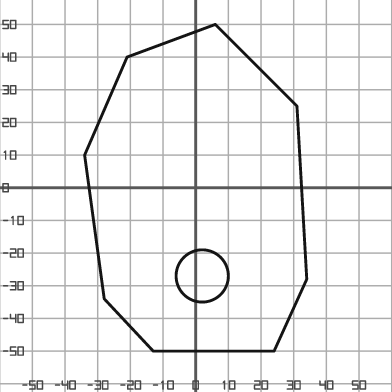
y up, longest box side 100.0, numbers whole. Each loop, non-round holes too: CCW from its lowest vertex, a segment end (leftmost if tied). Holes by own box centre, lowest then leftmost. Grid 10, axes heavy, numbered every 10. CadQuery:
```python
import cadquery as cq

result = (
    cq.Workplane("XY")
    .moveTo(-13.0, -50.0)
    .lineTo(24.0, -50.0)
    .lineTo(34.0, -28.0)
    .lineTo(31.0, 25.0)
    .lineTo(6.0, 50.0)
    .lineTo(-21.0, 40.0)
    .lineTo(-34.0, 10.0)
    .lineTo(-28.0, -34.0)
    .close()
    .moveTo(2.0, -27.0)
    .circle(8.0)
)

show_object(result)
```